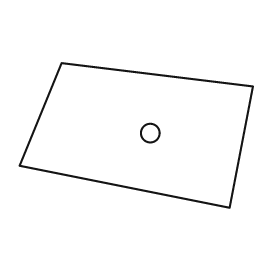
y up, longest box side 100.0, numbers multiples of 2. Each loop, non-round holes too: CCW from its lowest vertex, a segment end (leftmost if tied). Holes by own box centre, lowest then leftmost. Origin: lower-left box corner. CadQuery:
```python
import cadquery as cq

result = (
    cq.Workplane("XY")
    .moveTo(90.0, 0.0)
    .lineTo(100.0, 52.0)
    .lineTo(18.0, 62.0)
    .lineTo(0.0, 18.0)
    .close()
    .moveTo(56.0, 32.0)
    .circle(4.0)
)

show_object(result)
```